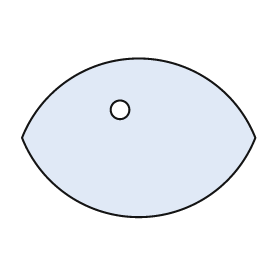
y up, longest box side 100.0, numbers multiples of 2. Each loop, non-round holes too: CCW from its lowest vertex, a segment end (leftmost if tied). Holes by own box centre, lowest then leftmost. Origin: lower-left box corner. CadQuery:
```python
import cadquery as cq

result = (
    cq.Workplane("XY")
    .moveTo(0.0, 34.0)
    .threePointArc((50.0, 0.0), (100.0, 34.0))
    .threePointArc((50.0, 68.0), (0.0, 34.0))
    .close()
    .moveTo(42.0, 46.0)
    .circle(4.0)
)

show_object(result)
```